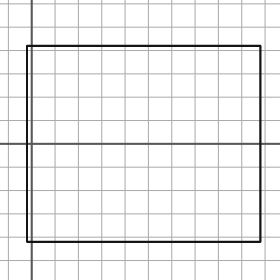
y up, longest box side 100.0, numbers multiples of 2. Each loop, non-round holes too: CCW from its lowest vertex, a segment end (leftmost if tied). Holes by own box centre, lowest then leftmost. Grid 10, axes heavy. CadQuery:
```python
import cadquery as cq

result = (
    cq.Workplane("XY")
    .moveTo(-2.0, -42.0)
    .lineTo(98.0, -42.0)
    .lineTo(98.0, 42.0)
    .lineTo(-2.0, 42.0)
    .close()
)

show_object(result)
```